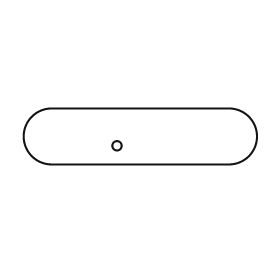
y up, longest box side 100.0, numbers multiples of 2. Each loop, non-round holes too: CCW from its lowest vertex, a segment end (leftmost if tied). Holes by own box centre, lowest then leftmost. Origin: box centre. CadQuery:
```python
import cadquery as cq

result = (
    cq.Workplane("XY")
    .moveTo(-38.0, -12.0)
    .lineTo(38.0, -12.0)
    .threePointArc((50.0, 0.0), (38.0, 12.0))
    .lineTo(-38.0, 12.0)
    .threePointArc((-50.0, 0.0), (-38.0, -12.0))
    .close()
    .moveTo(-10.0, -4.0)
    .circle(2.0)
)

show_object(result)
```